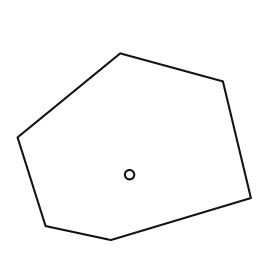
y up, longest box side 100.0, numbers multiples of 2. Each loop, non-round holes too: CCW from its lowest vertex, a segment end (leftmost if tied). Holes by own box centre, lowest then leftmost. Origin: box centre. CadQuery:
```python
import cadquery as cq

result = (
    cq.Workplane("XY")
    .moveTo(-10.0, -40.0)
    .lineTo(50.0, -22.0)
    .lineTo(38.0, 28.0)
    .lineTo(-6.0, 40.0)
    .lineTo(-50.0, 4.0)
    .lineTo(-38.0, -34.0)
    .close()
    .moveTo(-2.0, -12.0)
    .circle(2.0)
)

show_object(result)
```